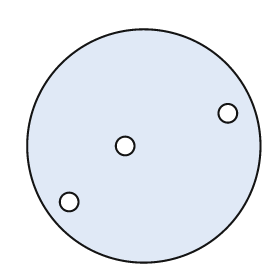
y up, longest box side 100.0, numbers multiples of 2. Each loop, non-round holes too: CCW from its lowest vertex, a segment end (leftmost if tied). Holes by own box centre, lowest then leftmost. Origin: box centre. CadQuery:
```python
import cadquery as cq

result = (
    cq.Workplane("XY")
    .moveTo(0.0, 0.0)
    .circle(50.0)
    .moveTo(-32.0, -24.0)
    .circle(4.0)
    .moveTo(-8.0, 0.0)
    .circle(4.0)
    .moveTo(36.0, 14.0)
    .circle(4.0)
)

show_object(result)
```